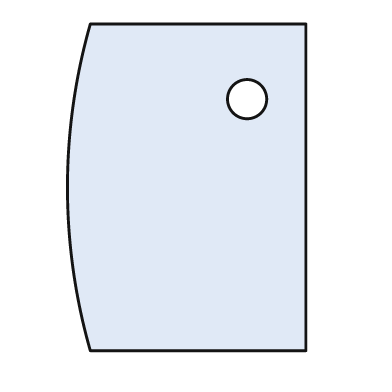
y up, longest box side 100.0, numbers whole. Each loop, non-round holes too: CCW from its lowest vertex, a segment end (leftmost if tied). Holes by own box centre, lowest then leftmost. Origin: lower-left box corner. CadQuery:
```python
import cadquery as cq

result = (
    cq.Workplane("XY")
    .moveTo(7.0, 0.0)
    .lineTo(73.0, 0.0)
    .lineTo(73.0, 100.0)
    .lineTo(7.0, 100.0)
    .threePointArc((0.0, 50.0), (7.0, 0.0))
    .close()
    .moveTo(55.0, 77.0)
    .circle(6.0)
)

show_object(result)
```